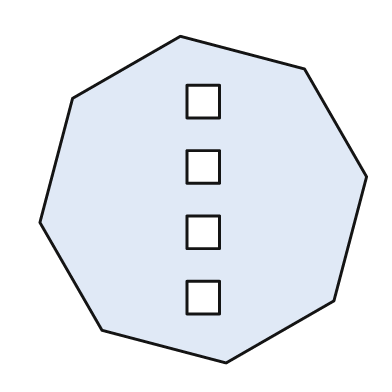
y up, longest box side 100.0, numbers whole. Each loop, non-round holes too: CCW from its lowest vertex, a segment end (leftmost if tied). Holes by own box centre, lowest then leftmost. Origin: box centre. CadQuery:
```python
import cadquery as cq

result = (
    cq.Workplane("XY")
    .moveTo(7.0, -50.0)
    .lineTo(40.0, -31.0)
    .lineTo(50.0, 7.0)
    .lineTo(31.0, 40.0)
    .lineTo(-7.0, 50.0)
    .lineTo(-40.0, 31.0)
    .lineTo(-50.0, -7.0)
    .lineTo(-31.0, -40.0)
    .close()
    .moveTo(-5.0, -35.0)
    .lineTo(5.0, -35.0)
    .lineTo(5.0, -25.0)
    .lineTo(-5.0, -25.0)
    .close()
    .moveTo(-5.0, -15.0)
    .lineTo(5.0, -15.0)
    .lineTo(5.0, -5.0)
    .lineTo(-5.0, -5.0)
    .close()
    .moveTo(-5.0, 5.0)
    .lineTo(5.0, 5.0)
    .lineTo(5.0, 15.0)
    .lineTo(-5.0, 15.0)
    .close()
    .moveTo(-5.0, 25.0)
    .lineTo(5.0, 25.0)
    .lineTo(5.0, 35.0)
    .lineTo(-5.0, 35.0)
    .close()
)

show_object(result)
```